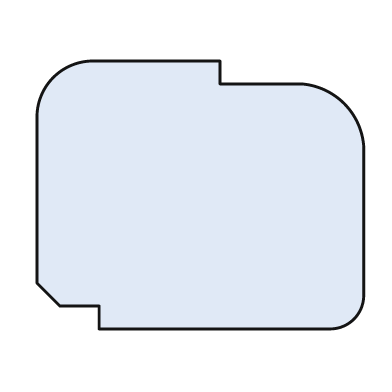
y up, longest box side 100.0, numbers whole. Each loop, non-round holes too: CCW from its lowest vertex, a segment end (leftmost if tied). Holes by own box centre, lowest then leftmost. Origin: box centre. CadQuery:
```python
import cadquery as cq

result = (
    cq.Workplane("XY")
    .moveTo(-31.0, -41.0)
    .lineTo(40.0, -41.0)
    .threePointArc((47.0, -38.0), (50.0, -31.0))
    .lineTo(50.0, 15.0)
    .threePointArc((44.0, 28.0), (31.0, 34.0))
    .lineTo(6.0, 34.0)
    .lineTo(6.0, 41.0)
    .lineTo(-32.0, 41.0)
    .threePointArc((-45.0, 36.0), (-50.0, 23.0))
    .lineTo(-50.0, -27.0)
    .lineTo(-43.0, -34.0)
    .lineTo(-31.0, -34.0)
    .close()
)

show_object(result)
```